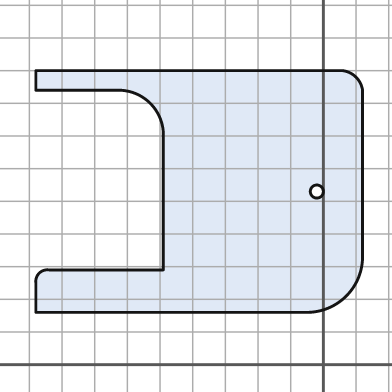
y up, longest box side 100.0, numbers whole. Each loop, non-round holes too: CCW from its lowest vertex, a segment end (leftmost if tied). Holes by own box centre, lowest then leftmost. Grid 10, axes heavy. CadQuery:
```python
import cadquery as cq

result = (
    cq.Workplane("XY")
    .moveTo(-88.0, 16.0)
    .lineTo(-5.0, 16.0)
    .threePointArc((7.0, 21.0), (12.0, 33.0))
    .lineTo(12.0, 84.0)
    .threePointArc((10.0, 88.0), (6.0, 90.0))
    .lineTo(-88.0, 90.0)
    .lineTo(-88.0, 84.0)
    .lineTo(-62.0, 84.0)
    .threePointArc((-53.0, 80.0), (-49.0, 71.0))
    .lineTo(-49.0, 29.0)
    .lineTo(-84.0, 29.0)
    .threePointArc((-87.0, 28.0), (-88.0, 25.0))
    .close()
    .moveTo(-2.0, 53.0)
    .circle(2.0)
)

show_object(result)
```